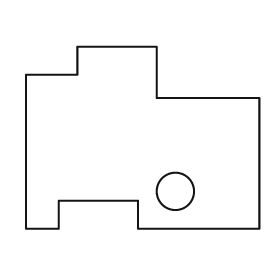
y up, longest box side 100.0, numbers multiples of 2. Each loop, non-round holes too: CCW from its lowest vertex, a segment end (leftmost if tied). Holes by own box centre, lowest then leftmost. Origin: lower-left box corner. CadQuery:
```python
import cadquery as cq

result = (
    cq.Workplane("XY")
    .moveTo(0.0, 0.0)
    .lineTo(14.0, 0.0)
    .lineTo(14.0, 12.0)
    .lineTo(48.0, 12.0)
    .lineTo(48.0, 0.0)
    .lineTo(100.0, 0.0)
    .lineTo(100.0, 56.0)
    .lineTo(56.0, 56.0)
    .lineTo(56.0, 78.0)
    .lineTo(22.0, 78.0)
    .lineTo(22.0, 66.0)
    .lineTo(0.0, 66.0)
    .close()
    .moveTo(64.0, 16.0)
    .circle(8.0)
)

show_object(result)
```